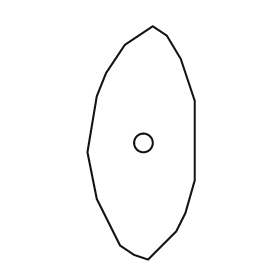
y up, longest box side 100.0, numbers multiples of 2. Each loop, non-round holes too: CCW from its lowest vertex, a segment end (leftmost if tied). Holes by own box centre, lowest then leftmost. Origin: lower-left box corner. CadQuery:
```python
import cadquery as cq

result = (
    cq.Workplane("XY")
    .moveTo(26.0, 0.0)
    .lineTo(38.0, 12.0)
    .lineTo(42.0, 20.0)
    .lineTo(46.0, 34.0)
    .lineTo(46.0, 68.0)
    .lineTo(40.0, 86.0)
    .lineTo(34.0, 96.0)
    .lineTo(28.0, 100.0)
    .lineTo(16.0, 92.0)
    .lineTo(8.0, 80.0)
    .lineTo(4.0, 70.0)
    .lineTo(0.0, 46.0)
    .lineTo(4.0, 26.0)
    .lineTo(14.0, 6.0)
    .lineTo(20.0, 2.0)
    .close()
    .moveTo(24.0, 50.0)
    .circle(4.0)
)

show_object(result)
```